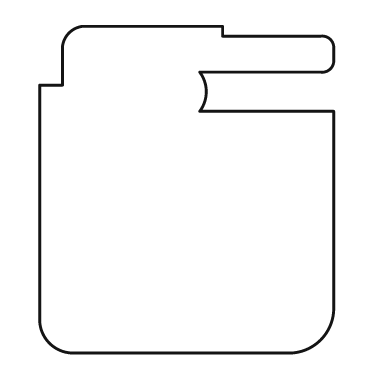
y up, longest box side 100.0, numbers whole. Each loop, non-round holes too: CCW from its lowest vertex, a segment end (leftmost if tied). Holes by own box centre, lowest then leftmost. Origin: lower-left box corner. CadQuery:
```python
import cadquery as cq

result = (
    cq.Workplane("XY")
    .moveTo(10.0, 0.0)
    .lineTo(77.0, 0.0)
    .threePointArc((86.0, 4.0), (90.0, 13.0))
    .lineTo(90.0, 74.0)
    .lineTo(49.0, 74.0)
    .threePointArc((51.0, 80.0), (49.0, 86.0))
    .lineTo(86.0, 86.0)
    .threePointArc((89.0, 87.0), (90.0, 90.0))
    .lineTo(90.0, 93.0)
    .threePointArc((89.0, 96.0), (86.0, 97.0))
    .lineTo(56.0, 97.0)
    .lineTo(56.0, 100.0)
    .lineTo(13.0, 100.0)
    .threePointArc((9.0, 98.0), (7.0, 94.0))
    .lineTo(7.0, 82.0)
    .lineTo(0.0, 82.0)
    .lineTo(0.0, 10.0)
    .threePointArc((3.0, 3.0), (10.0, 0.0))
    .close()
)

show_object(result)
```